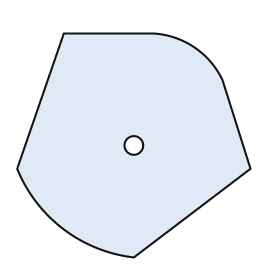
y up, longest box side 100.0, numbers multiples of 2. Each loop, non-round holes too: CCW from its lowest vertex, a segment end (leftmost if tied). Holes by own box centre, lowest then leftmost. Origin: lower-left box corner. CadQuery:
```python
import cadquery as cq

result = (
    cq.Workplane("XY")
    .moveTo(50.0, 0.0)
    .lineTo(100.0, 38.0)
    .lineTo(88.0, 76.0)
    .threePointArc((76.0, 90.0), (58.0, 96.0))
    .lineTo(20.0, 96.0)
    .lineTo(0.0, 38.0)
    .threePointArc((20.0, 12.0), (50.0, 0.0))
    .close()
    .moveTo(50.0, 48.0)
    .circle(4.0)
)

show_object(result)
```